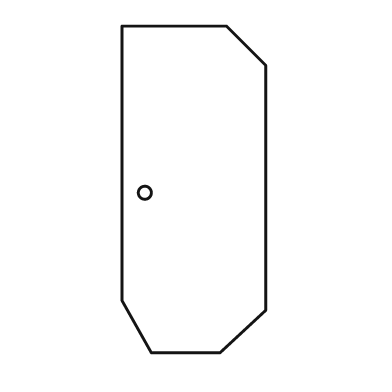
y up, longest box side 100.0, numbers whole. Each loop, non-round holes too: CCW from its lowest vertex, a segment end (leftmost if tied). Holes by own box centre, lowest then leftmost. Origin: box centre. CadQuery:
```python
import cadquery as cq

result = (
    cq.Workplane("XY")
    .moveTo(-13.0, -50.0)
    .lineTo(8.0, -50.0)
    .lineTo(22.0, -37.0)
    .lineTo(22.0, 38.0)
    .lineTo(10.0, 50.0)
    .lineTo(-22.0, 50.0)
    .lineTo(-22.0, -34.0)
    .close()
    .moveTo(-15.0, -1.0)
    .circle(2.0)
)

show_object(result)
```